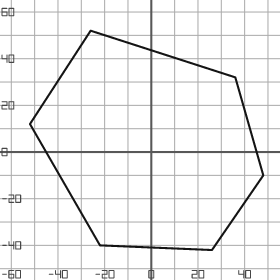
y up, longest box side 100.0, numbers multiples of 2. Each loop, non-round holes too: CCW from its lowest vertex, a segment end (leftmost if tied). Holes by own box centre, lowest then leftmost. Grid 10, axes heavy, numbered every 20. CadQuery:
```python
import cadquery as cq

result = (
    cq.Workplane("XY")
    .moveTo(26.0, -42.0)
    .lineTo(48.0, -10.0)
    .lineTo(36.0, 32.0)
    .lineTo(-26.0, 52.0)
    .lineTo(-52.0, 12.0)
    .lineTo(-22.0, -40.0)
    .close()
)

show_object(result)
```